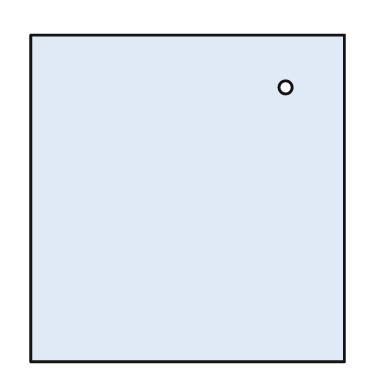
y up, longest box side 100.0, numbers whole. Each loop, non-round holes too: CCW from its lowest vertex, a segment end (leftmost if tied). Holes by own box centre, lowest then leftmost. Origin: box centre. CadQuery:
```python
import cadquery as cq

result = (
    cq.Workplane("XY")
    .moveTo(-48.0, -50.0)
    .lineTo(48.0, -50.0)
    .lineTo(48.0, 50.0)
    .lineTo(-48.0, 50.0)
    .close()
    .moveTo(30.0, 34.0)
    .circle(2.0)
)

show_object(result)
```